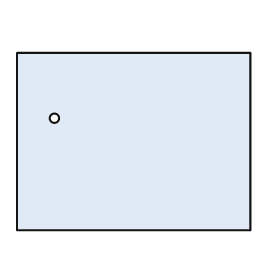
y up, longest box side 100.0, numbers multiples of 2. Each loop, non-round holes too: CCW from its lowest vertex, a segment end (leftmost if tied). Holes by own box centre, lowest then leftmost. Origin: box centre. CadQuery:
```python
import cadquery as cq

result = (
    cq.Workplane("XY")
    .moveTo(-50.0, -38.0)
    .lineTo(50.0, -38.0)
    .lineTo(50.0, 38.0)
    .lineTo(-50.0, 38.0)
    .close()
    .moveTo(-34.0, 10.0)
    .circle(2.0)
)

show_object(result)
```